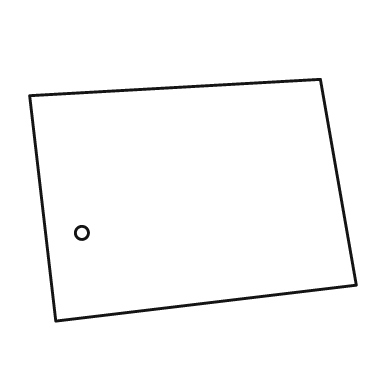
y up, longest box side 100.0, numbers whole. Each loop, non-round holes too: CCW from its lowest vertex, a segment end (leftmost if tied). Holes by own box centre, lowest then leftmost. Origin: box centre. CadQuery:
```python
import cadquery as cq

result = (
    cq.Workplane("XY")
    .moveTo(-42.0, -37.0)
    .lineTo(50.0, -26.0)
    .lineTo(39.0, 37.0)
    .lineTo(-50.0, 32.0)
    .close()
    .moveTo(-34.0, -10.0)
    .circle(2.0)
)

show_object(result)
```